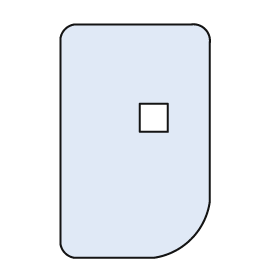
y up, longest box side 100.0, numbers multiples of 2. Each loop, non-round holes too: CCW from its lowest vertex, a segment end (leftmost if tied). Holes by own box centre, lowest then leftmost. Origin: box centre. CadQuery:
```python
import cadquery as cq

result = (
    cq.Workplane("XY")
    .moveTo(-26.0, -50.0)
    .lineTo(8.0, -50.0)
    .threePointArc((24.0, -42.0), (32.0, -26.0))
    .lineTo(32.0, 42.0)
    .threePointArc((30.0, 48.0), (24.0, 50.0))
    .lineTo(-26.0, 50.0)
    .threePointArc((-30.0, 48.0), (-32.0, 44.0))
    .lineTo(-32.0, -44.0)
    .threePointArc((-30.0, -48.0), (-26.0, -50.0))
    .close()
    .moveTo(2.0, 4.0)
    .lineTo(14.0, 4.0)
    .lineTo(14.0, 16.0)
    .lineTo(2.0, 16.0)
    .close()
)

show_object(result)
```